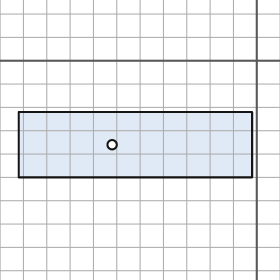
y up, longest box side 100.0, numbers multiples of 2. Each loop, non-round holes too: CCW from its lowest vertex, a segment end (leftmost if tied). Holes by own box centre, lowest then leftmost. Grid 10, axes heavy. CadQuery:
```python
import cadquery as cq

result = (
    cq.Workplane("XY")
    .moveTo(-102.0, -50.0)
    .lineTo(-2.0, -50.0)
    .lineTo(-2.0, -22.0)
    .lineTo(-102.0, -22.0)
    .close()
    .moveTo(-62.0, -36.0)
    .circle(2.0)
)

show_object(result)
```